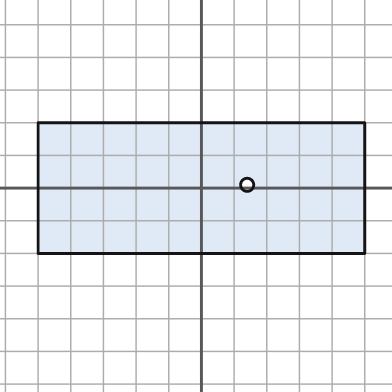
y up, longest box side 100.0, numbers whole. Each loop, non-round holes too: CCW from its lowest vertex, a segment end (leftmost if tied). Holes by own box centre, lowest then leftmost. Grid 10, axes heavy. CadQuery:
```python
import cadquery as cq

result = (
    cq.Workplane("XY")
    .moveTo(-50.0, -20.0)
    .lineTo(50.0, -20.0)
    .lineTo(50.0, 20.0)
    .lineTo(-50.0, 20.0)
    .close()
    .moveTo(14.0, 1.0)
    .circle(2.0)
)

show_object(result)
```